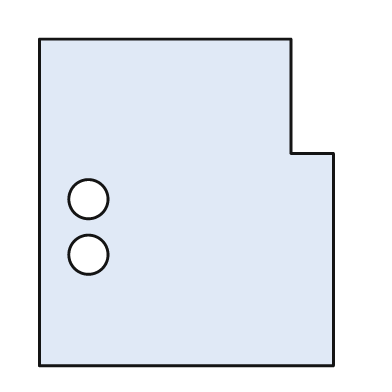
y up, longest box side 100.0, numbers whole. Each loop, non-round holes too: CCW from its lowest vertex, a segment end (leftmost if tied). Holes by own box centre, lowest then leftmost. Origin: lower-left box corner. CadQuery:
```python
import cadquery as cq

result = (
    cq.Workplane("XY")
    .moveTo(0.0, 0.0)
    .lineTo(90.0, 0.0)
    .lineTo(90.0, 65.0)
    .lineTo(77.0, 65.0)
    .lineTo(77.0, 100.0)
    .lineTo(0.0, 100.0)
    .close()
    .moveTo(15.0, 34.0)
    .circle(6.0)
    .moveTo(15.0, 51.0)
    .circle(6.0)
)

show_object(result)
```